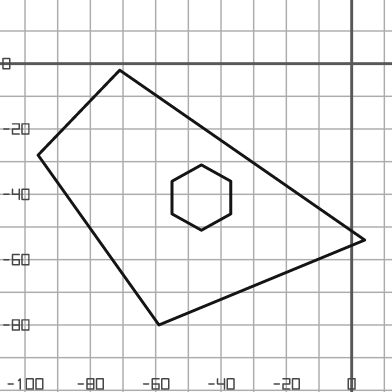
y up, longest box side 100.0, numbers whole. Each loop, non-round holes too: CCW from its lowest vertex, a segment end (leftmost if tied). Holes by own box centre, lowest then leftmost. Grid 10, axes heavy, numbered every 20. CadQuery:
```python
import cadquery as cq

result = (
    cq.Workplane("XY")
    .moveTo(-59.0, -80.0)
    .lineTo(4.0, -54.0)
    .lineTo(-71.0, -2.0)
    .lineTo(-96.0, -28.0)
    .close()
    .moveTo(-46.0, -51.0)
    .lineTo(-37.0, -46.0)
    .lineTo(-37.0, -36.0)
    .lineTo(-46.0, -31.0)
    .lineTo(-55.0, -36.0)
    .lineTo(-55.0, -46.0)
    .close()
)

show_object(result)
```